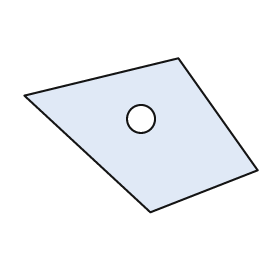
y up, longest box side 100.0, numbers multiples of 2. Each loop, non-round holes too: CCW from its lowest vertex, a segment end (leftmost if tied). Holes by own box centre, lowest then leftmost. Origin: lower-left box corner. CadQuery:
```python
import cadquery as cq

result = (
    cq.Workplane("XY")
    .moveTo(54.0, 0.0)
    .lineTo(100.0, 18.0)
    .lineTo(66.0, 66.0)
    .lineTo(0.0, 50.0)
    .close()
    .moveTo(50.0, 40.0)
    .circle(6.0)
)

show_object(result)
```